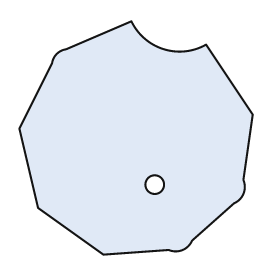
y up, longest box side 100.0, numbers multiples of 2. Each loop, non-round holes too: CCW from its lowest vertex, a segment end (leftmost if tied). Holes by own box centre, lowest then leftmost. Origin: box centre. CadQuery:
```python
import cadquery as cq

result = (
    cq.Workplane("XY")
    .moveTo(-14.0, -50.0)
    .lineTo(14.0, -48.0)
    .threePointArc((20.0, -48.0), (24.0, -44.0))
    .lineTo(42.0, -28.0)
    .threePointArc((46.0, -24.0), (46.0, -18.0))
    .lineTo(50.0, 10.0)
    .lineTo(30.0, 40.0)
    .threePointArc((12.0, 38.0), (-2.0, 50.0))
    .lineTo(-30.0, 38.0)
    .threePointArc((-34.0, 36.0), (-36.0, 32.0))
    .lineTo(-50.0, 4.0)
    .lineTo(-42.0, -30.0)
    .close()
    .moveTo(8.0, -20.0)
    .circle(4.0)
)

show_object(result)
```